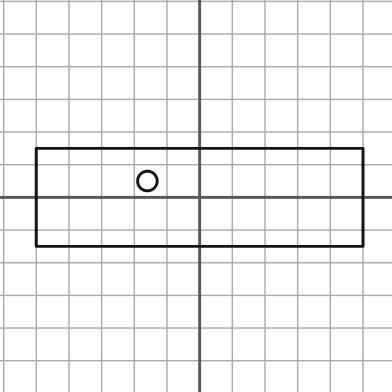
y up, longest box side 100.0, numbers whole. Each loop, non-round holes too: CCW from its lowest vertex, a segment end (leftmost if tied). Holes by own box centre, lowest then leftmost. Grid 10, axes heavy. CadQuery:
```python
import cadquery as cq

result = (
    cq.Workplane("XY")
    .moveTo(-50.0, -15.0)
    .lineTo(50.0, -15.0)
    .lineTo(50.0, 15.0)
    .lineTo(-50.0, 15.0)
    .close()
    .moveTo(-16.0, 5.0)
    .circle(3.0)
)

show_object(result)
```